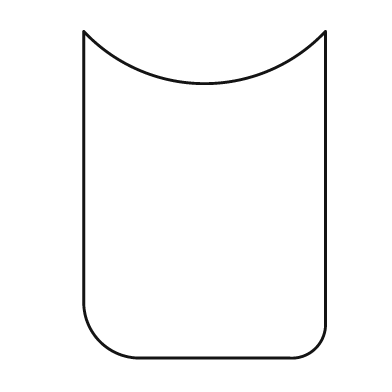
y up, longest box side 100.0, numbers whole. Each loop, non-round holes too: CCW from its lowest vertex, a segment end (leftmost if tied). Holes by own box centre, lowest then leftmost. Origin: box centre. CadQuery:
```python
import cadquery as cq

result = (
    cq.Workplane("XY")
    .moveTo(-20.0, -50.0)
    .lineTo(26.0, -50.0)
    .threePointArc((34.0, -47.0), (37.0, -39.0))
    .lineTo(37.0, 50.0)
    .threePointArc((0.0, 34.0), (-37.0, 50.0))
    .lineTo(-37.0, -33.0)
    .threePointArc((-32.0, -45.0), (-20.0, -50.0))
    .close()
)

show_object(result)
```